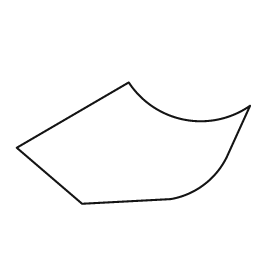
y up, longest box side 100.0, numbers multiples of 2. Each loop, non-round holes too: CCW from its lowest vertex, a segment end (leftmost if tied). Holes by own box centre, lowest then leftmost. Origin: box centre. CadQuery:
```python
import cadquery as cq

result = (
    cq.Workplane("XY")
    .moveTo(-22.0, -26.0)
    .lineTo(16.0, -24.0)
    .threePointArc((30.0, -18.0), (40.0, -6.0))
    .lineTo(50.0, 16.0)
    .threePointArc((22.0, 10.0), (-2.0, 26.0))
    .lineTo(-50.0, -2.0)
    .close()
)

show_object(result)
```